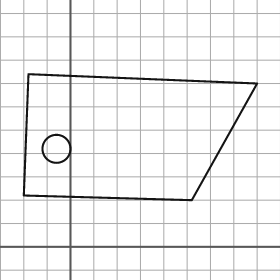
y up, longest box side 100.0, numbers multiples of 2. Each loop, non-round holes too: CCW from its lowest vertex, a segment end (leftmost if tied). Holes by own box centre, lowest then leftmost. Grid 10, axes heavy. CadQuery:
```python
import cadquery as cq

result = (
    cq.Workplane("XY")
    .moveTo(52.0, 20.0)
    .lineTo(80.0, 70.0)
    .lineTo(-18.0, 74.0)
    .lineTo(-20.0, 22.0)
    .close()
    .moveTo(-6.0, 42.0)
    .circle(6.0)
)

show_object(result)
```